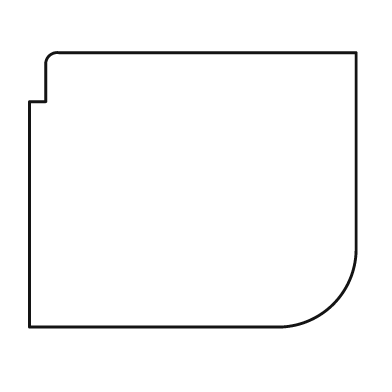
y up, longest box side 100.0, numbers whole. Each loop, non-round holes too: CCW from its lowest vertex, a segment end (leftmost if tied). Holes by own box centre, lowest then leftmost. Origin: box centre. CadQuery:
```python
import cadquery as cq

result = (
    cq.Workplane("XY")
    .moveTo(-50.0, -42.0)
    .lineTo(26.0, -42.0)
    .threePointArc((43.0, -35.0), (50.0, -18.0))
    .lineTo(50.0, 42.0)
    .lineTo(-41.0, 42.0)
    .threePointArc((-44.0, 41.0), (-45.0, 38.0))
    .lineTo(-45.0, 27.0)
    .lineTo(-50.0, 27.0)
    .close()
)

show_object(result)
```